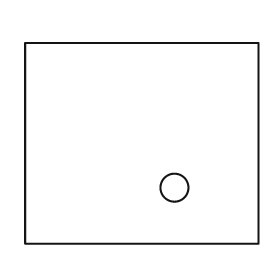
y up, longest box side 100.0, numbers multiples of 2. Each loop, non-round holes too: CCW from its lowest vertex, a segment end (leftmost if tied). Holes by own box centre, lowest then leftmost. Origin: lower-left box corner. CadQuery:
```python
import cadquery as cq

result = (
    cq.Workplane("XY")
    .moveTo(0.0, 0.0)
    .lineTo(100.0, 0.0)
    .lineTo(100.0, 86.0)
    .lineTo(0.0, 86.0)
    .close()
    .moveTo(64.0, 24.0)
    .circle(6.0)
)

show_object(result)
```